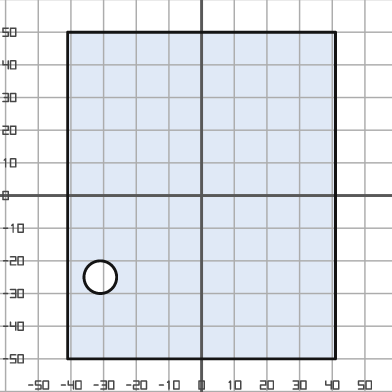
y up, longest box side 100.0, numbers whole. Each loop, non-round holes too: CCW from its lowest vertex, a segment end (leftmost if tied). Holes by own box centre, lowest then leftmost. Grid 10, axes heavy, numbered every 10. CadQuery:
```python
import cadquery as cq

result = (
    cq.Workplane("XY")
    .moveTo(-41.0, -50.0)
    .lineTo(41.0, -50.0)
    .lineTo(41.0, 50.0)
    .lineTo(-41.0, 50.0)
    .close()
    .moveTo(-31.0, -25.0)
    .circle(5.0)
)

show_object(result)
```